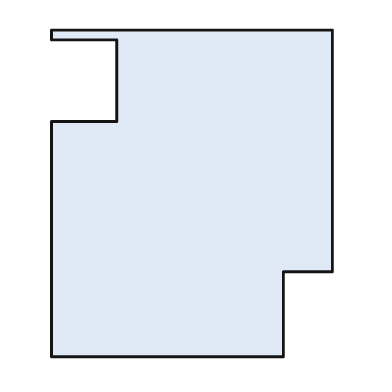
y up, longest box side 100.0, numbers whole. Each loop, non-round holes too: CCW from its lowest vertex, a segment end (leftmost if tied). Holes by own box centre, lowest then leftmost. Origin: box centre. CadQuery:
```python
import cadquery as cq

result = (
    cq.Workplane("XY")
    .moveTo(-43.0, -50.0)
    .lineTo(28.0, -50.0)
    .lineTo(28.0, -24.0)
    .lineTo(43.0, -24.0)
    .lineTo(43.0, 50.0)
    .lineTo(-43.0, 50.0)
    .lineTo(-43.0, 47.0)
    .lineTo(-23.0, 47.0)
    .lineTo(-23.0, 22.0)
    .lineTo(-43.0, 22.0)
    .close()
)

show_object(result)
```